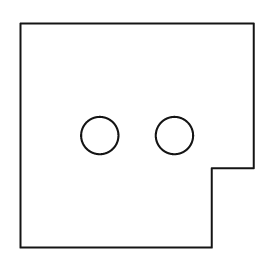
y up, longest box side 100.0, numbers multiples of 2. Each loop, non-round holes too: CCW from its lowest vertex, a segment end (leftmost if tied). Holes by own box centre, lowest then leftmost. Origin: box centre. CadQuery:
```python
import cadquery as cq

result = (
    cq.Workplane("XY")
    .moveTo(-50.0, -48.0)
    .lineTo(32.0, -48.0)
    .lineTo(32.0, -14.0)
    .lineTo(50.0, -14.0)
    .lineTo(50.0, 48.0)
    .lineTo(-50.0, 48.0)
    .close()
    .moveTo(-16.0, 0.0)
    .circle(8.0)
    .moveTo(16.0, 0.0)
    .circle(8.0)
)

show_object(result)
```